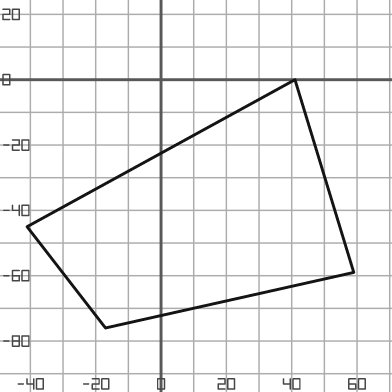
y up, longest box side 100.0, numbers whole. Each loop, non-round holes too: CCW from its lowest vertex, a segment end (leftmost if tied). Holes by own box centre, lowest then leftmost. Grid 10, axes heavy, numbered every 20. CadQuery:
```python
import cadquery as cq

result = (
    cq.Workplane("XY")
    .moveTo(-17.0, -76.0)
    .lineTo(59.0, -59.0)
    .lineTo(41.0, 0.0)
    .lineTo(-41.0, -45.0)
    .close()
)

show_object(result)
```